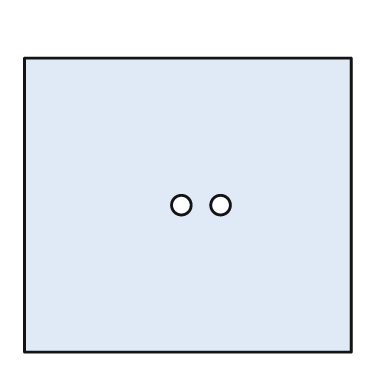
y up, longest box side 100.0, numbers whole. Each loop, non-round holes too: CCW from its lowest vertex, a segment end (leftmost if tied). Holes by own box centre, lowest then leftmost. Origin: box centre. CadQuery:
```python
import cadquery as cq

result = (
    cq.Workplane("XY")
    .moveTo(-50.0, -45.0)
    .lineTo(50.0, -45.0)
    .lineTo(50.0, 45.0)
    .lineTo(-50.0, 45.0)
    .close()
    .moveTo(-2.0, 0.0)
    .circle(3.0)
    .moveTo(10.0, 0.0)
    .circle(3.0)
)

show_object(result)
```